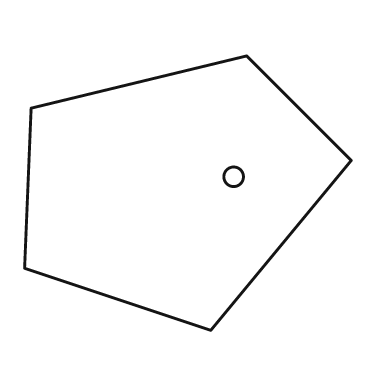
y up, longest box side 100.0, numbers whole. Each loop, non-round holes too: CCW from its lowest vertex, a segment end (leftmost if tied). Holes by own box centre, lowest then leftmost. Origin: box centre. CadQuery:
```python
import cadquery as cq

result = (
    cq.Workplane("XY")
    .moveTo(7.0, -42.0)
    .lineTo(50.0, 10.0)
    .lineTo(18.0, 42.0)
    .lineTo(-48.0, 26.0)
    .lineTo(-50.0, -23.0)
    .close()
    .moveTo(14.0, 5.0)
    .circle(3.0)
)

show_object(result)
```